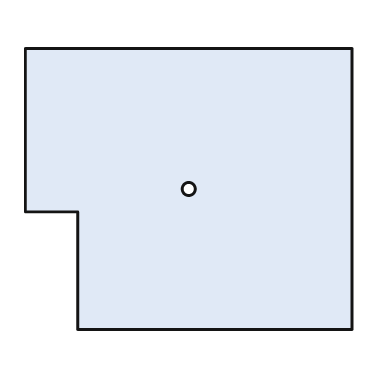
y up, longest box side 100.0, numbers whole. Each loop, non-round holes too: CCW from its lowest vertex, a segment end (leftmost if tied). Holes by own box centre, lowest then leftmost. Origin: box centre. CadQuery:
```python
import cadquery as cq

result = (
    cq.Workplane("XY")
    .moveTo(-34.0, -43.0)
    .lineTo(50.0, -43.0)
    .lineTo(50.0, 43.0)
    .lineTo(-50.0, 43.0)
    .lineTo(-50.0, -7.0)
    .lineTo(-34.0, -7.0)
    .close()
    .moveTo(0.0, 0.0)
    .circle(2.0)
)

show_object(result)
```